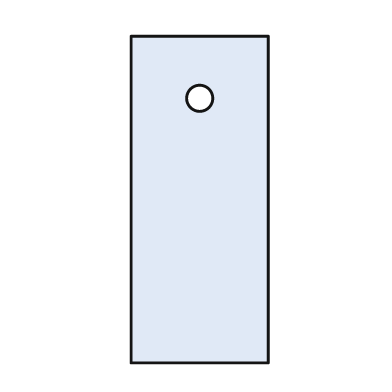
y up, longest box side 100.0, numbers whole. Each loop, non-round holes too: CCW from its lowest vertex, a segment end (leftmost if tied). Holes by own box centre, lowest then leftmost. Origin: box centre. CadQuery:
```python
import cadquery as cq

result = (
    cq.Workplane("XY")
    .moveTo(-21.0, -50.0)
    .lineTo(21.0, -50.0)
    .lineTo(21.0, 50.0)
    .lineTo(-21.0, 50.0)
    .close()
    .moveTo(0.0, 31.0)
    .circle(4.0)
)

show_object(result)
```